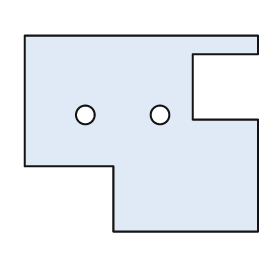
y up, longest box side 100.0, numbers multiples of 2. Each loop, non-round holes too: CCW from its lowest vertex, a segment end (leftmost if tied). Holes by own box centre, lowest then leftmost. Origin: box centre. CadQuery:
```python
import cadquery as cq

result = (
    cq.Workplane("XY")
    .moveTo(-12.0, -42.0)
    .lineTo(50.0, -42.0)
    .lineTo(50.0, 6.0)
    .lineTo(22.0, 6.0)
    .lineTo(22.0, 34.0)
    .lineTo(50.0, 34.0)
    .lineTo(50.0, 42.0)
    .lineTo(-50.0, 42.0)
    .lineTo(-50.0, -14.0)
    .lineTo(-12.0, -14.0)
    .close()
    .moveTo(-24.0, 8.0)
    .circle(4.0)
    .moveTo(8.0, 8.0)
    .circle(4.0)
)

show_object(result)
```